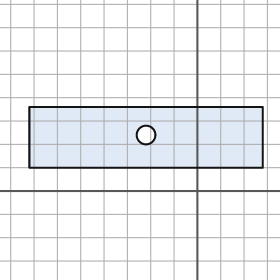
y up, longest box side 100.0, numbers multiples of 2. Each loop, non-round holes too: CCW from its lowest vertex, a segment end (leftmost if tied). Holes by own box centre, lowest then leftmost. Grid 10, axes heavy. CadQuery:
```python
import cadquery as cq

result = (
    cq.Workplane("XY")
    .moveTo(-72.0, 10.0)
    .lineTo(28.0, 10.0)
    .lineTo(28.0, 36.0)
    .lineTo(-72.0, 36.0)
    .close()
    .moveTo(-22.0, 24.0)
    .circle(4.0)
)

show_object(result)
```